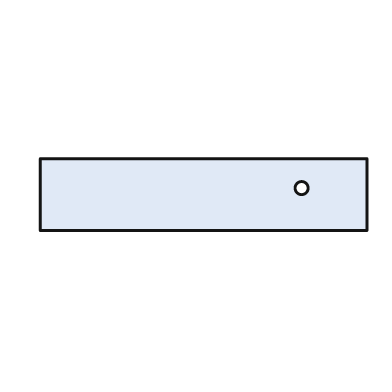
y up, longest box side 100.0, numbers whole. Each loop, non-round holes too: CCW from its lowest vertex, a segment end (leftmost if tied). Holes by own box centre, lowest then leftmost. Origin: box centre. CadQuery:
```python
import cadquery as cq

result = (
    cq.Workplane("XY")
    .moveTo(-50.0, -11.0)
    .lineTo(50.0, -11.0)
    .lineTo(50.0, 11.0)
    .lineTo(-50.0, 11.0)
    .close()
    .moveTo(30.0, 2.0)
    .circle(2.0)
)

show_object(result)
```